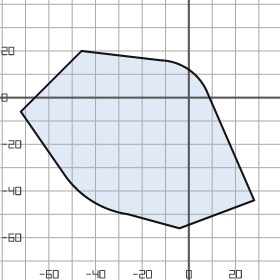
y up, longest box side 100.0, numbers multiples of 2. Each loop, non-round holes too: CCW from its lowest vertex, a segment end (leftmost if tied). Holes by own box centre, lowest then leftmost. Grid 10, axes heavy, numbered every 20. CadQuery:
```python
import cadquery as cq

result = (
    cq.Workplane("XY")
    .moveTo(-4.0, -56.0)
    .lineTo(28.0, -44.0)
    .lineTo(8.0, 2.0)
    .threePointArc((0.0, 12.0), (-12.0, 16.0))
    .lineTo(-46.0, 20.0)
    .lineTo(-72.0, -6.0)
    .lineTo(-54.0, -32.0)
    .threePointArc((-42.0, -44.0), (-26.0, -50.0))
    .close()
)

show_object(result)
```